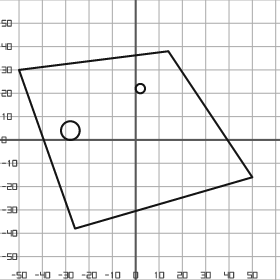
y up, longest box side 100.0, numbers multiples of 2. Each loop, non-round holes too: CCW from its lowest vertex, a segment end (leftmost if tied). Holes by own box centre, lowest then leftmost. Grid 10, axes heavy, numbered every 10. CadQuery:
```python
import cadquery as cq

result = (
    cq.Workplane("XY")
    .moveTo(-26.0, -38.0)
    .lineTo(50.0, -16.0)
    .lineTo(14.0, 38.0)
    .lineTo(-50.0, 30.0)
    .close()
    .moveTo(-28.0, 4.0)
    .circle(4.0)
    .moveTo(2.0, 22.0)
    .circle(2.0)
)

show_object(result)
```